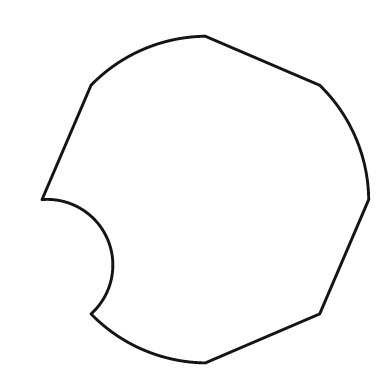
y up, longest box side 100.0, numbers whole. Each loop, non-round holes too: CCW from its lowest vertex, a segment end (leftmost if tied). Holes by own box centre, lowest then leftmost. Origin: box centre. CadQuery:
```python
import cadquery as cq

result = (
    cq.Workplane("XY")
    .moveTo(0.0, -50.0)
    .lineTo(35.0, -35.0)
    .lineTo(50.0, 0.0)
    .threePointArc((46.0, 19.0), (35.0, 35.0))
    .lineTo(0.0, 50.0)
    .threePointArc((-19.0, 46.0), (-35.0, 35.0))
    .lineTo(-50.0, 0.0)
    .threePointArc((-30.0, -12.0), (-35.0, -35.0))
    .threePointArc((-19.0, -46.0), (0.0, -50.0))
    .close()
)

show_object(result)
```